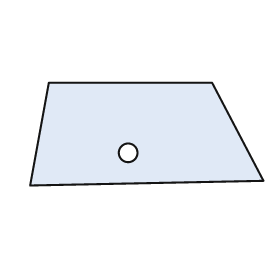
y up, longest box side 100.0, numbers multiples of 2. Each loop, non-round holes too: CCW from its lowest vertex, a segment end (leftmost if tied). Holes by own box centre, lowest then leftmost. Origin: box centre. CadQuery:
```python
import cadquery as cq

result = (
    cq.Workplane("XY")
    .moveTo(-50.0, -22.0)
    .lineTo(50.0, -20.0)
    .lineTo(28.0, 22.0)
    .lineTo(-42.0, 22.0)
    .close()
    .moveTo(-8.0, -8.0)
    .circle(4.0)
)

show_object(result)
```